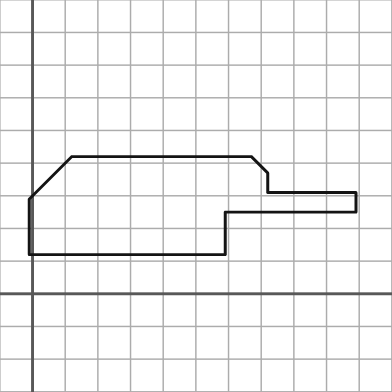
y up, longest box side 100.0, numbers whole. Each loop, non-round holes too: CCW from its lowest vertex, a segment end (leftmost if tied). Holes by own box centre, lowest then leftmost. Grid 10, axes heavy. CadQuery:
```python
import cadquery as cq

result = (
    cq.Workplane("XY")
    .moveTo(-1.0, 12.0)
    .lineTo(59.0, 12.0)
    .lineTo(59.0, 25.0)
    .lineTo(99.0, 25.0)
    .lineTo(99.0, 31.0)
    .lineTo(72.0, 31.0)
    .lineTo(72.0, 37.0)
    .lineTo(67.0, 42.0)
    .lineTo(12.0, 42.0)
    .lineTo(-1.0, 29.0)
    .close()
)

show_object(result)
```